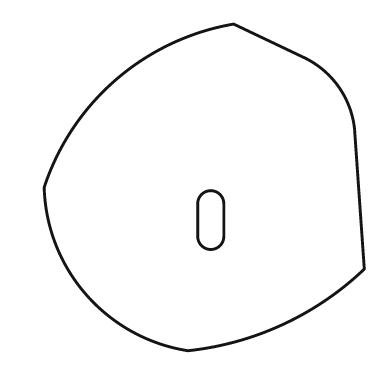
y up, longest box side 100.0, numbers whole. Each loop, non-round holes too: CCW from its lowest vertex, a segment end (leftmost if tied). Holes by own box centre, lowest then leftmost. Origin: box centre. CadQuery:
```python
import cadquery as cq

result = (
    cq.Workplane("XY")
    .moveTo(-5.0, -50.0)
    .threePointArc((24.0, -42.0), (49.0, -25.0))
    .lineTo(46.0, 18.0)
    .threePointArc((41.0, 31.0), (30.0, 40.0))
    .lineTo(9.0, 50.0)
    .threePointArc((-27.0, 33.0), (-49.0, 0.0))
    .threePointArc((-36.0, -33.0), (-5.0, -50.0))
    .close()
    .moveTo(-2.0, -15.0)
    .threePointArc((2.0, -19.0), (6.0, -15.0))
    .lineTo(6.0, -5.0)
    .threePointArc((2.0, -1.0), (-2.0, -5.0))
    .close()
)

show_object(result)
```